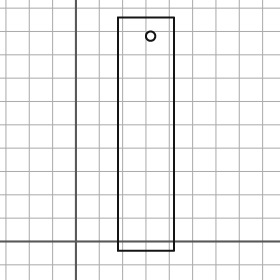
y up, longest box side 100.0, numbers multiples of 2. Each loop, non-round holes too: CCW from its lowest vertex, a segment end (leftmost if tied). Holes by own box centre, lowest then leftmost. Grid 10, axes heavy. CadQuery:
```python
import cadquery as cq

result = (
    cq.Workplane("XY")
    .moveTo(18.0, -4.0)
    .lineTo(42.0, -4.0)
    .lineTo(42.0, 96.0)
    .lineTo(18.0, 96.0)
    .close()
    .moveTo(32.0, 88.0)
    .circle(2.0)
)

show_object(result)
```